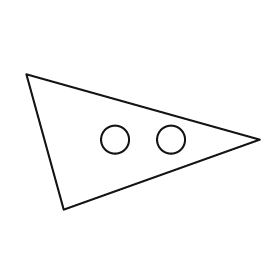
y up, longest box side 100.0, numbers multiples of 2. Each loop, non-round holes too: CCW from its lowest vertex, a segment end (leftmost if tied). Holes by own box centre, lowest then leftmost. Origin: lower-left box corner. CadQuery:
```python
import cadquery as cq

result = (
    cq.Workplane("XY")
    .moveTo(16.0, 0.0)
    .lineTo(100.0, 30.0)
    .lineTo(0.0, 58.0)
    .close()
    .moveTo(38.0, 30.0)
    .circle(6.0)
    .moveTo(62.0, 30.0)
    .circle(6.0)
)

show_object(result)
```